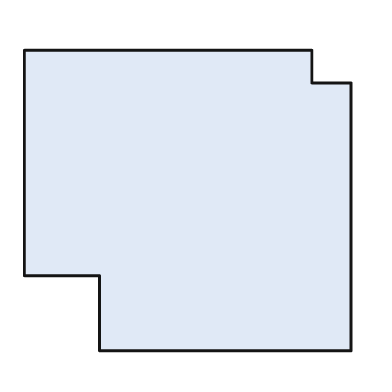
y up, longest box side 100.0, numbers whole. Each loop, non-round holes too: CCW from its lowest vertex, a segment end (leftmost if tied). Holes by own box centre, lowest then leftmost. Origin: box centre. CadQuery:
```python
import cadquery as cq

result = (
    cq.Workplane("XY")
    .moveTo(-27.0, -46.0)
    .lineTo(50.0, -46.0)
    .lineTo(50.0, 36.0)
    .lineTo(38.0, 36.0)
    .lineTo(38.0, 46.0)
    .lineTo(-50.0, 46.0)
    .lineTo(-50.0, -23.0)
    .lineTo(-27.0, -23.0)
    .close()
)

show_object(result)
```